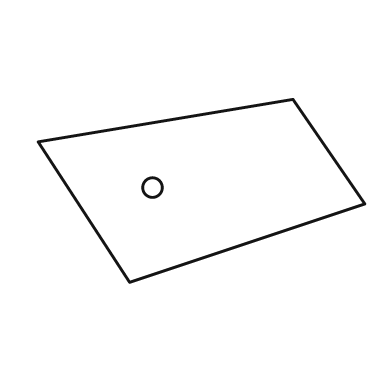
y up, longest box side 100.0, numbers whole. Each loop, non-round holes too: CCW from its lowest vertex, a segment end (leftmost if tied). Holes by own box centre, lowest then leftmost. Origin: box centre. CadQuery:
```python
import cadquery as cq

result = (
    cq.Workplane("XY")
    .moveTo(-22.0, -28.0)
    .lineTo(50.0, -4.0)
    .lineTo(28.0, 28.0)
    .lineTo(-50.0, 15.0)
    .close()
    .moveTo(-15.0, 1.0)
    .circle(3.0)
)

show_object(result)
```